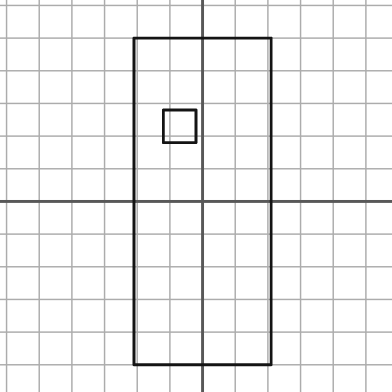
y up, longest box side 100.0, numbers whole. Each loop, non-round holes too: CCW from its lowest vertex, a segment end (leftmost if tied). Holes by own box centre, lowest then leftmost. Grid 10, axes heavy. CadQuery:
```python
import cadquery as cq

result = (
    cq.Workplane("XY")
    .moveTo(-21.0, -50.0)
    .lineTo(21.0, -50.0)
    .lineTo(21.0, 50.0)
    .lineTo(-21.0, 50.0)
    .close()
    .moveTo(-12.0, 18.0)
    .lineTo(-2.0, 18.0)
    .lineTo(-2.0, 28.0)
    .lineTo(-12.0, 28.0)
    .close()
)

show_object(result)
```